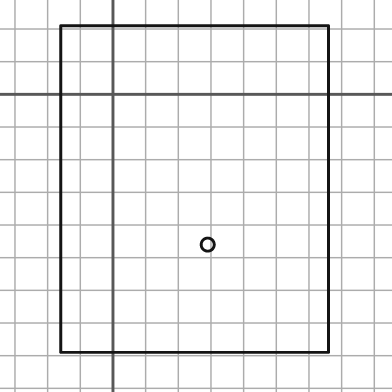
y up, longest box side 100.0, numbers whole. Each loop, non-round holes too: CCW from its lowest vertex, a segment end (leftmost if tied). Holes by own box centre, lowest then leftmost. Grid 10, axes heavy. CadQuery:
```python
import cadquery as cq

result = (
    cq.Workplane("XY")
    .moveTo(-16.0, -79.0)
    .lineTo(66.0, -79.0)
    .lineTo(66.0, 21.0)
    .lineTo(-16.0, 21.0)
    .close()
    .moveTo(29.0, -46.0)
    .circle(2.0)
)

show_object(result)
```